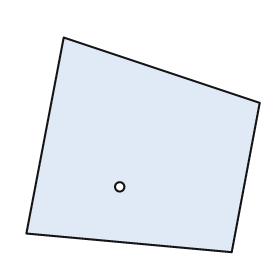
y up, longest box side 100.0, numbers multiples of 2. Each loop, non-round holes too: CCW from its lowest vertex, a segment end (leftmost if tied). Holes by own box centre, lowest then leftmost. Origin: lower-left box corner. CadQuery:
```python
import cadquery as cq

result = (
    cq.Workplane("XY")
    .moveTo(88.0, 0.0)
    .lineTo(100.0, 64.0)
    .lineTo(16.0, 92.0)
    .lineTo(0.0, 8.0)
    .close()
    .moveTo(40.0, 28.0)
    .circle(2.0)
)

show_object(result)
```